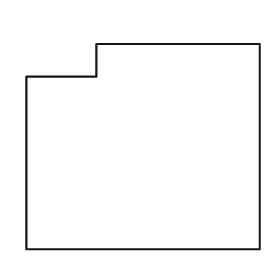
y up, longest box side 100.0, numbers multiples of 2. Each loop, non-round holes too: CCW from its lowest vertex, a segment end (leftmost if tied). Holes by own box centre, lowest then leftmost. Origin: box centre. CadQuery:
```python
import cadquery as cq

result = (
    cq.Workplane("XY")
    .moveTo(-50.0, -44.0)
    .lineTo(50.0, -44.0)
    .lineTo(50.0, 44.0)
    .lineTo(-20.0, 44.0)
    .lineTo(-20.0, 30.0)
    .lineTo(-50.0, 30.0)
    .close()
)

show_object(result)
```